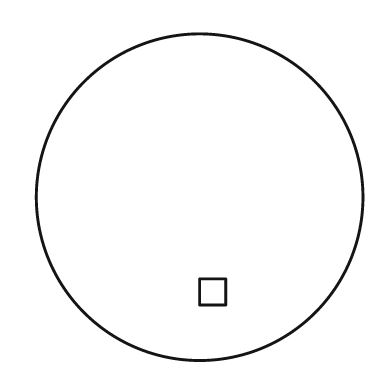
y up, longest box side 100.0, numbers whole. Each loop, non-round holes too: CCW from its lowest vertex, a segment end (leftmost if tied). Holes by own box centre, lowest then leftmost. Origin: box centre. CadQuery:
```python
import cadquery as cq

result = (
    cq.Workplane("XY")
    .moveTo(0.0, 0.0)
    .circle(50.0)
    .moveTo(0.0, -33.0)
    .lineTo(8.0, -33.0)
    .lineTo(8.0, -25.0)
    .lineTo(0.0, -25.0)
    .close()
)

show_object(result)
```